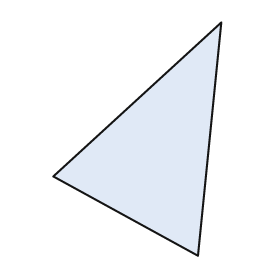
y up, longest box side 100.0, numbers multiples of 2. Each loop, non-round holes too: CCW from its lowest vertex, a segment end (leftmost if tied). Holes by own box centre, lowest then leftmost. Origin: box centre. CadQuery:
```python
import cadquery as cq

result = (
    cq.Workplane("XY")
    .moveTo(26.0, -50.0)
    .lineTo(36.0, 50.0)
    .lineTo(-36.0, -16.0)
    .close()
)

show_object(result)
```